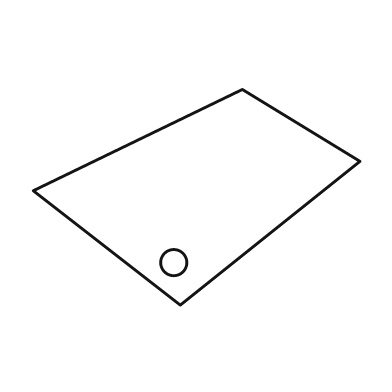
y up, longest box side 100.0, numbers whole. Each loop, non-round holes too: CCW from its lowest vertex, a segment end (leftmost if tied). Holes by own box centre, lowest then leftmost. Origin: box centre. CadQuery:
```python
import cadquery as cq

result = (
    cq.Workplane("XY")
    .moveTo(-5.0, -33.0)
    .lineTo(50.0, 11.0)
    .lineTo(14.0, 33.0)
    .lineTo(-50.0, 2.0)
    .close()
    .moveTo(-7.0, -20.0)
    .circle(4.0)
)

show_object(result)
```